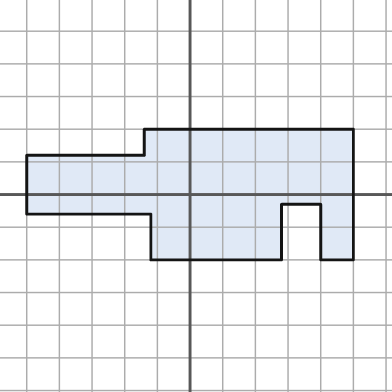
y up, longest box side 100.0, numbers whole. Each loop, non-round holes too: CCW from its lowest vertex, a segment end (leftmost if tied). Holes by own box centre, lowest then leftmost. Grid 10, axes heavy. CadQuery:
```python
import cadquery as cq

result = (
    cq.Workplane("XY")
    .moveTo(-12.0, -20.0)
    .lineTo(28.0, -20.0)
    .lineTo(28.0, -3.0)
    .lineTo(40.0, -3.0)
    .lineTo(40.0, -20.0)
    .lineTo(50.0, -20.0)
    .lineTo(50.0, 20.0)
    .lineTo(-14.0, 20.0)
    .lineTo(-14.0, 12.0)
    .lineTo(-50.0, 12.0)
    .lineTo(-50.0, -6.0)
    .lineTo(-12.0, -6.0)
    .close()
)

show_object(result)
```